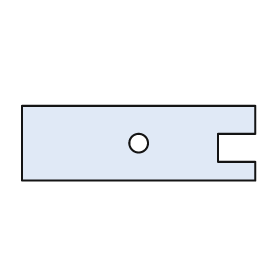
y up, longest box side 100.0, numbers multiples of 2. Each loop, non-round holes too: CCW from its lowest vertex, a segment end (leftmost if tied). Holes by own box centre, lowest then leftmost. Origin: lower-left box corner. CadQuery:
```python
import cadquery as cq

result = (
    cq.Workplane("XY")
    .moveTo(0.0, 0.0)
    .lineTo(100.0, 0.0)
    .lineTo(100.0, 8.0)
    .lineTo(84.0, 8.0)
    .lineTo(84.0, 20.0)
    .lineTo(100.0, 20.0)
    .lineTo(100.0, 32.0)
    .lineTo(0.0, 32.0)
    .close()
    .moveTo(50.0, 16.0)
    .circle(4.0)
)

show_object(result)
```